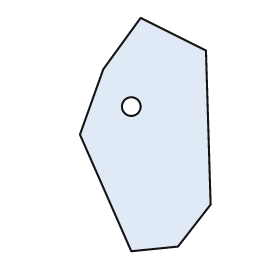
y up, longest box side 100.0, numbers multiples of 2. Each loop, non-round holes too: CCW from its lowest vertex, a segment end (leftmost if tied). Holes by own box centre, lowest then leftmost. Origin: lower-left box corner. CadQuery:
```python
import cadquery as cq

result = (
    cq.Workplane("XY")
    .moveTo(22.0, 0.0)
    .lineTo(42.0, 2.0)
    .lineTo(56.0, 20.0)
    .lineTo(54.0, 86.0)
    .lineTo(26.0, 100.0)
    .lineTo(10.0, 78.0)
    .lineTo(0.0, 50.0)
    .close()
    .moveTo(22.0, 62.0)
    .circle(4.0)
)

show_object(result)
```